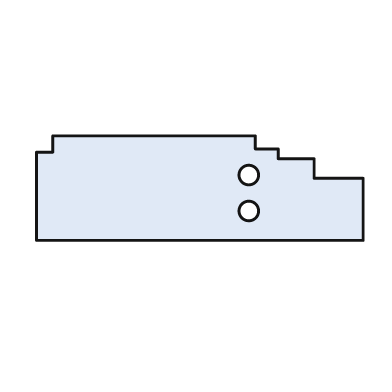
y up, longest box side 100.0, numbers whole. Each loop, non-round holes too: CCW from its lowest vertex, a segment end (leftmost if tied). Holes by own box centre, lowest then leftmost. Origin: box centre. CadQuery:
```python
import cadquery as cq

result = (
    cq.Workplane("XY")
    .moveTo(-50.0, -16.0)
    .lineTo(50.0, -16.0)
    .lineTo(50.0, 3.0)
    .lineTo(35.0, 3.0)
    .lineTo(35.0, 9.0)
    .lineTo(24.0, 9.0)
    .lineTo(24.0, 12.0)
    .lineTo(17.0, 12.0)
    .lineTo(17.0, 16.0)
    .lineTo(-45.0, 16.0)
    .lineTo(-45.0, 11.0)
    .lineTo(-50.0, 11.0)
    .close()
    .moveTo(15.0, -7.0)
    .circle(3.0)
    .moveTo(15.0, 4.0)
    .circle(3.0)
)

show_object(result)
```